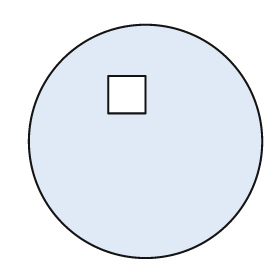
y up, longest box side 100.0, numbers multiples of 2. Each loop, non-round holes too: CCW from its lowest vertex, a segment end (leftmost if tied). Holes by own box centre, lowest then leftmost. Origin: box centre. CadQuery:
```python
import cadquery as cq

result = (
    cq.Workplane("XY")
    .moveTo(0.0, 0.0)
    .circle(50.0)
    .moveTo(-16.0, 12.0)
    .lineTo(0.0, 12.0)
    .lineTo(0.0, 28.0)
    .lineTo(-16.0, 28.0)
    .close()
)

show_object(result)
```